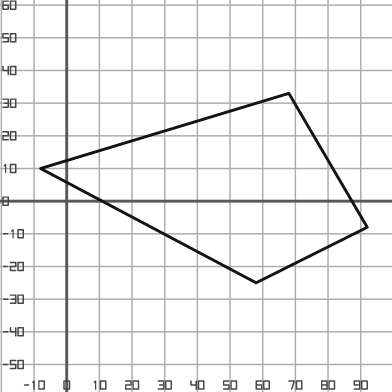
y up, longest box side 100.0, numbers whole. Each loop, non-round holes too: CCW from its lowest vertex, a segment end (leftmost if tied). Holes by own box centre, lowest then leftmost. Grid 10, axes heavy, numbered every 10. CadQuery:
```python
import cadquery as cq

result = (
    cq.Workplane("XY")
    .moveTo(58.0, -25.0)
    .lineTo(92.0, -8.0)
    .lineTo(68.0, 33.0)
    .lineTo(-8.0, 10.0)
    .close()
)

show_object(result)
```